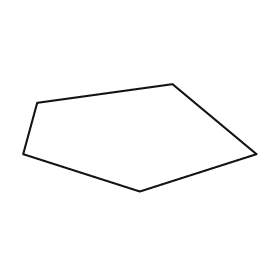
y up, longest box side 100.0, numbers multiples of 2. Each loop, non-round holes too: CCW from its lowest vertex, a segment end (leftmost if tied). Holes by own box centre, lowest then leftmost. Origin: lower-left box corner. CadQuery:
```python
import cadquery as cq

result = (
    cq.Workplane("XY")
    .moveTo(50.0, 0.0)
    .lineTo(100.0, 16.0)
    .lineTo(64.0, 46.0)
    .lineTo(6.0, 38.0)
    .lineTo(0.0, 16.0)
    .close()
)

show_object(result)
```